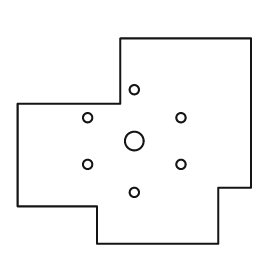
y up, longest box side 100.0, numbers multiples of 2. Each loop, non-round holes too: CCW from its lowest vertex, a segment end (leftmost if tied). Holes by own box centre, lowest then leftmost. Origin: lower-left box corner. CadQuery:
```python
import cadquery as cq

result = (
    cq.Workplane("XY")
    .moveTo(34.0, 0.0)
    .lineTo(86.0, 0.0)
    .lineTo(86.0, 24.0)
    .lineTo(100.0, 24.0)
    .lineTo(100.0, 88.0)
    .lineTo(44.0, 88.0)
    .lineTo(44.0, 60.0)
    .lineTo(0.0, 60.0)
    .lineTo(0.0, 16.0)
    .lineTo(34.0, 16.0)
    .close()
    .moveTo(50.0, 22.0)
    .circle(2.0)
    .moveTo(30.0, 34.0)
    .circle(2.0)
    .moveTo(70.0, 34.0)
    .circle(2.0)
    .moveTo(50.0, 44.0)
    .circle(4.0)
    .moveTo(30.0, 54.0)
    .circle(2.0)
    .moveTo(70.0, 54.0)
    .circle(2.0)
    .moveTo(50.0, 66.0)
    .circle(2.0)
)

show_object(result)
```